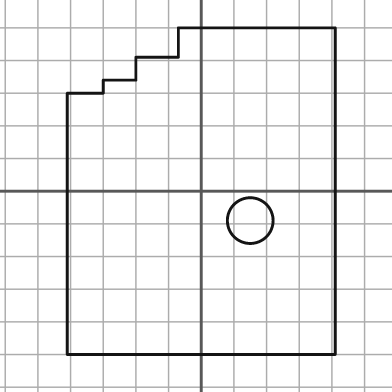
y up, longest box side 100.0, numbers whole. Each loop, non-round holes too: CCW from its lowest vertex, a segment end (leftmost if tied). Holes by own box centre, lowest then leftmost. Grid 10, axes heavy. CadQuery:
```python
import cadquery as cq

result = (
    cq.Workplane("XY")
    .moveTo(-41.0, -50.0)
    .lineTo(41.0, -50.0)
    .lineTo(41.0, 50.0)
    .lineTo(-7.0, 50.0)
    .lineTo(-7.0, 41.0)
    .lineTo(-20.0, 41.0)
    .lineTo(-20.0, 34.0)
    .lineTo(-30.0, 34.0)
    .lineTo(-30.0, 30.0)
    .lineTo(-41.0, 30.0)
    .close()
    .moveTo(15.0, -9.0)
    .circle(7.0)
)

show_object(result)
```